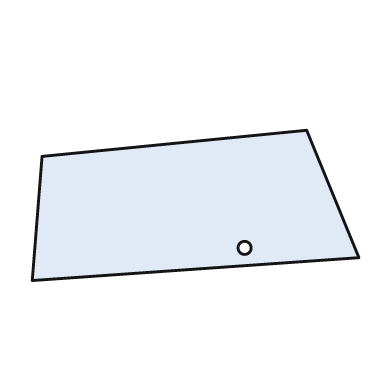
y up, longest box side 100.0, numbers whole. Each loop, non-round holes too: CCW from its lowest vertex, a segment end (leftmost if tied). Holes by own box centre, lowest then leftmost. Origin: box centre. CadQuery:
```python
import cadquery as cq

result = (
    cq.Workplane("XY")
    .moveTo(-50.0, -23.0)
    .lineTo(50.0, -16.0)
    .lineTo(34.0, 23.0)
    .lineTo(-47.0, 15.0)
    .close()
    .moveTo(15.0, -13.0)
    .circle(2.0)
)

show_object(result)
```